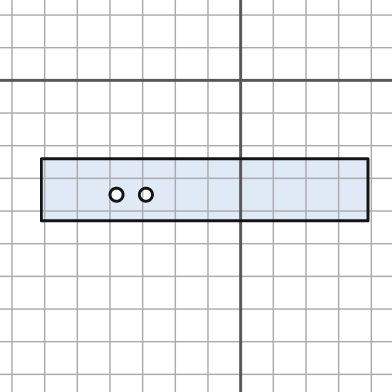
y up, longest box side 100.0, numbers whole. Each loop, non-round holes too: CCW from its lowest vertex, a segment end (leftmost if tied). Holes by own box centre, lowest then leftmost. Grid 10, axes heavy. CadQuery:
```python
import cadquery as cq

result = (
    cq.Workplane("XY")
    .moveTo(-61.0, -43.0)
    .lineTo(39.0, -43.0)
    .lineTo(39.0, -24.0)
    .lineTo(-61.0, -24.0)
    .close()
    .moveTo(-38.0, -35.0)
    .circle(2.0)
    .moveTo(-29.0, -35.0)
    .circle(2.0)
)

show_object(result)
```